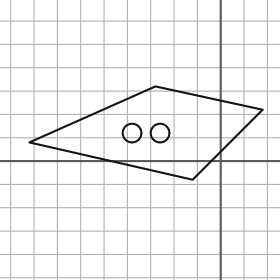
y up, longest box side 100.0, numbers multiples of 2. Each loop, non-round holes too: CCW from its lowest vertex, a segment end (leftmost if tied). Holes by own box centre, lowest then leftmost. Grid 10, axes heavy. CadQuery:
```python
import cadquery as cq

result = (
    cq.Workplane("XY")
    .moveTo(-12.0, -8.0)
    .lineTo(18.0, 22.0)
    .lineTo(-28.0, 32.0)
    .lineTo(-82.0, 8.0)
    .close()
    .moveTo(-38.0, 12.0)
    .circle(4.0)
    .moveTo(-26.0, 12.0)
    .circle(4.0)
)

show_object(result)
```